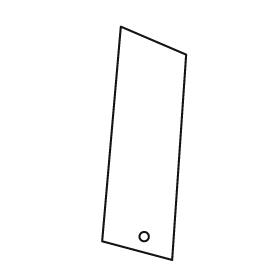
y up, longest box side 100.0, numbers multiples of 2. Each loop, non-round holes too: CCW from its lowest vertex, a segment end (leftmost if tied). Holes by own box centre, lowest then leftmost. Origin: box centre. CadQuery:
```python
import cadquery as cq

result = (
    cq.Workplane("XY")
    .moveTo(12.0, -50.0)
    .lineTo(18.0, 38.0)
    .lineTo(-10.0, 50.0)
    .lineTo(-18.0, -42.0)
    .close()
    .moveTo(0.0, -40.0)
    .circle(2.0)
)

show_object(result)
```